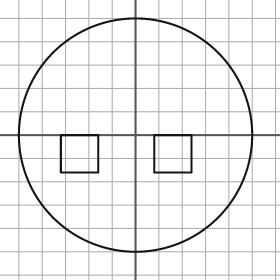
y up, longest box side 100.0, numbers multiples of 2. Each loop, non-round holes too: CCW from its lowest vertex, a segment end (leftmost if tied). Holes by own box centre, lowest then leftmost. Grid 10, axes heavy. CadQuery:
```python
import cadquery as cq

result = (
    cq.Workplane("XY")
    .moveTo(0.0, 0.0)
    .circle(50.0)
    .moveTo(-32.0, -16.0)
    .lineTo(-16.0, -16.0)
    .lineTo(-16.0, 0.0)
    .lineTo(-32.0, 0.0)
    .close()
    .moveTo(8.0, -16.0)
    .lineTo(24.0, -16.0)
    .lineTo(24.0, 0.0)
    .lineTo(8.0, 0.0)
    .close()
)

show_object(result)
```